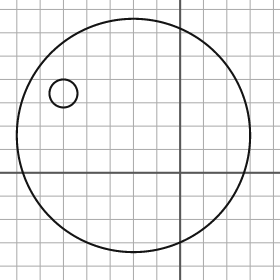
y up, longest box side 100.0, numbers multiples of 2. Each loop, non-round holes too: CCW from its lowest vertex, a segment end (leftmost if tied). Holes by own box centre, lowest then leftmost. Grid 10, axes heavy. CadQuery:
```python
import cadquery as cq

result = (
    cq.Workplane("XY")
    .moveTo(-20.0, 16.0)
    .circle(50.0)
    .moveTo(-50.0, 34.0)
    .circle(6.0)
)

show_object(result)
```